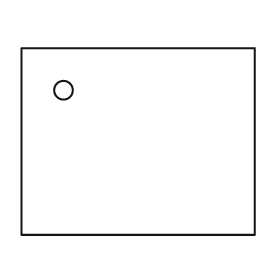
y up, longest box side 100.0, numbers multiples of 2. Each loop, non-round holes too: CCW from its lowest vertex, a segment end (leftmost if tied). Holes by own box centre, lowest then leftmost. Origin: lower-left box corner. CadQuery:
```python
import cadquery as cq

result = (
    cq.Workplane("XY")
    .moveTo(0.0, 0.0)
    .lineTo(100.0, 0.0)
    .lineTo(100.0, 80.0)
    .lineTo(0.0, 80.0)
    .close()
    .moveTo(18.0, 62.0)
    .circle(4.0)
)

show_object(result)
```